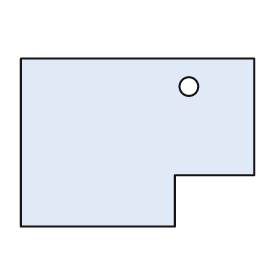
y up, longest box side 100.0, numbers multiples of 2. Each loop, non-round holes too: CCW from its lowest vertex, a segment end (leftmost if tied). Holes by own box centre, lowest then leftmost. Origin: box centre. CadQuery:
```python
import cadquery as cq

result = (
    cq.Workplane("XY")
    .moveTo(-50.0, -36.0)
    .lineTo(16.0, -36.0)
    .lineTo(16.0, -14.0)
    .lineTo(50.0, -14.0)
    .lineTo(50.0, 36.0)
    .lineTo(-50.0, 36.0)
    .close()
    .moveTo(22.0, 24.0)
    .circle(4.0)
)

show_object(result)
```